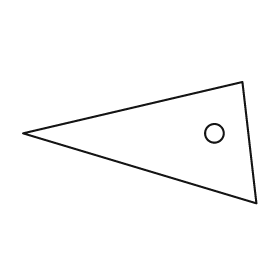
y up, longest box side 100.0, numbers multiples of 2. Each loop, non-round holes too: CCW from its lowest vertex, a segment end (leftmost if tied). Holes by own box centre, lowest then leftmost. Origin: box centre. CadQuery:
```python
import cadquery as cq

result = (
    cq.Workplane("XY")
    .moveTo(50.0, -26.0)
    .lineTo(44.0, 26.0)
    .lineTo(-50.0, 4.0)
    .close()
    .moveTo(32.0, 4.0)
    .circle(4.0)
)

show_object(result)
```